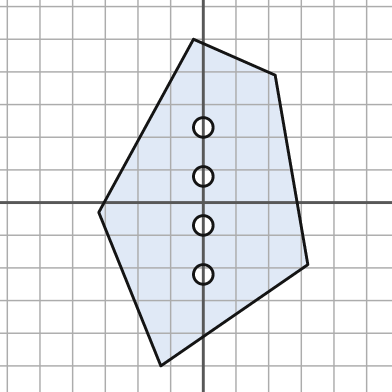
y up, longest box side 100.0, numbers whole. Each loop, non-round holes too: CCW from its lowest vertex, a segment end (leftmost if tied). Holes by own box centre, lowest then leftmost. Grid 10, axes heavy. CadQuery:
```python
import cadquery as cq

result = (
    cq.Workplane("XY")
    .moveTo(-13.0, -50.0)
    .lineTo(32.0, -19.0)
    .lineTo(22.0, 39.0)
    .lineTo(-3.0, 50.0)
    .lineTo(-32.0, -3.0)
    .close()
    .moveTo(0.0, -22.0)
    .circle(3.0)
    .moveTo(0.0, -7.0)
    .circle(3.0)
    .moveTo(0.0, 8.0)
    .circle(3.0)
    .moveTo(0.0, 23.0)
    .circle(3.0)
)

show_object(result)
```